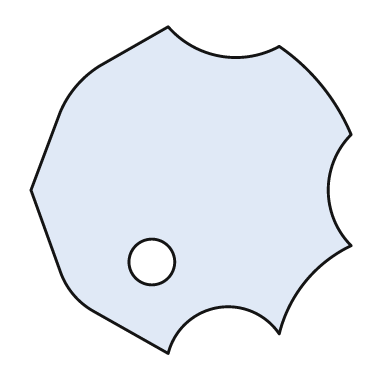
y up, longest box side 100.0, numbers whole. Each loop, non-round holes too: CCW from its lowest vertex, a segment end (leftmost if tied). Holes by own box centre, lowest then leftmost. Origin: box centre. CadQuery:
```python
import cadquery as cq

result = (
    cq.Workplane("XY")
    .moveTo(-7.0, -50.0)
    .threePointArc((8.0, -36.0), (27.0, -44.0))
    .threePointArc((35.0, -28.0), (49.0, -17.0))
    .threePointArc((42.0, 0.0), (49.0, 17.0))
    .threePointArc((40.0, 32.0), (27.0, 44.0))
    .threePointArc((9.0, 41.0), (-7.0, 50.0))
    .lineTo(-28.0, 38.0)
    .threePointArc((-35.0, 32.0), (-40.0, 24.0))
    .lineTo(-49.0, 0.0)
    .lineTo(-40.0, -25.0)
    .threePointArc((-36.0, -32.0), (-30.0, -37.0))
    .close()
    .moveTo(-12.0, -22.0)
    .circle(7.0)
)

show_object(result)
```